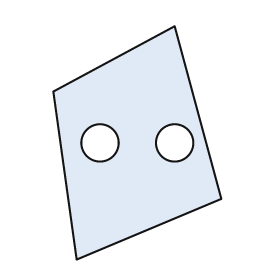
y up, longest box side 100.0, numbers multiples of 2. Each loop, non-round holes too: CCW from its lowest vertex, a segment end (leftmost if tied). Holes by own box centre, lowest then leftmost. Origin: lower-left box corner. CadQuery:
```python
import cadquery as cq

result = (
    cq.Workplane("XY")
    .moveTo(10.0, 0.0)
    .lineTo(72.0, 26.0)
    .lineTo(52.0, 100.0)
    .lineTo(0.0, 72.0)
    .close()
    .moveTo(20.0, 50.0)
    .circle(8.0)
    .moveTo(52.0, 50.0)
    .circle(8.0)
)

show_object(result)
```